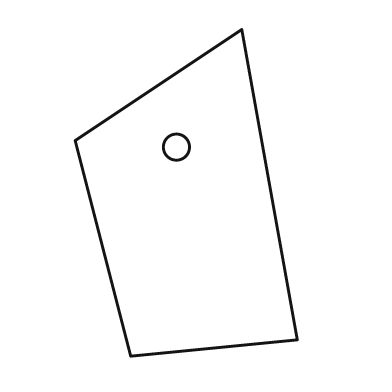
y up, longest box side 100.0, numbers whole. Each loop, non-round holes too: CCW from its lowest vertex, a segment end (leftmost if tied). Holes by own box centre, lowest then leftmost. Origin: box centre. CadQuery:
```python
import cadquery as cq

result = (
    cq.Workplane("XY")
    .moveTo(-17.0, -50.0)
    .lineTo(34.0, -45.0)
    .lineTo(17.0, 50.0)
    .lineTo(-34.0, 16.0)
    .close()
    .moveTo(-3.0, 14.0)
    .circle(4.0)
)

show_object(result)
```